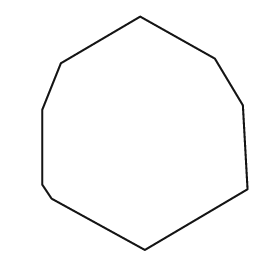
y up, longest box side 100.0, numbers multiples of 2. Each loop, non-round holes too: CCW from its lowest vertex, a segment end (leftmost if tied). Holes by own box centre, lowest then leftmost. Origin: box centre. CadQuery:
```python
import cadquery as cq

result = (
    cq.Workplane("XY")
    .moveTo(0.0, -50.0)
    .lineTo(44.0, -24.0)
    .lineTo(42.0, 12.0)
    .lineTo(30.0, 32.0)
    .lineTo(-2.0, 50.0)
    .lineTo(-36.0, 30.0)
    .lineTo(-44.0, 10.0)
    .lineTo(-44.0, -22.0)
    .lineTo(-40.0, -28.0)
    .close()
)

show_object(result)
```